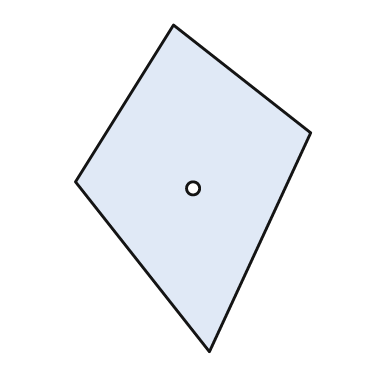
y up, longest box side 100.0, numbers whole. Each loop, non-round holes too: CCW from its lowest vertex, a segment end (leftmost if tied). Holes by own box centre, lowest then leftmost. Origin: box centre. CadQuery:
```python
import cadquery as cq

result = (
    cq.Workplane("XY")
    .moveTo(5.0, -50.0)
    .lineTo(36.0, 17.0)
    .lineTo(-6.0, 50.0)
    .lineTo(-36.0, 2.0)
    .close()
    .moveTo(0.0, 0.0)
    .circle(2.0)
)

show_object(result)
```